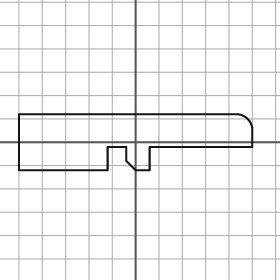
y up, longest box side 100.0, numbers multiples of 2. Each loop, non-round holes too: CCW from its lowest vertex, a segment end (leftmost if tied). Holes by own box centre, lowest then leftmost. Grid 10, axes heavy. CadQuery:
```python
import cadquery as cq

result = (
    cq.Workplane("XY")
    .moveTo(-50.0, -12.0)
    .lineTo(-12.0, -12.0)
    .lineTo(-12.0, -2.0)
    .lineTo(-4.0, -2.0)
    .lineTo(-4.0, -8.0)
    .lineTo(0.0, -12.0)
    .lineTo(6.0, -12.0)
    .lineTo(6.0, -2.0)
    .lineTo(50.0, -2.0)
    .lineTo(50.0, 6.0)
    .threePointArc((48.0, 10.0), (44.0, 12.0))
    .lineTo(-50.0, 12.0)
    .close()
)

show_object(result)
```